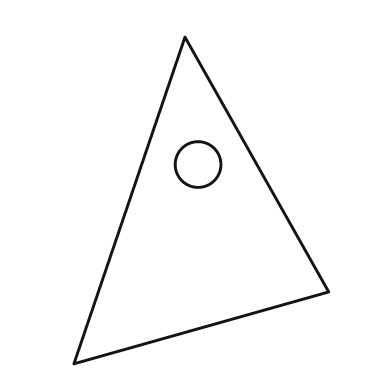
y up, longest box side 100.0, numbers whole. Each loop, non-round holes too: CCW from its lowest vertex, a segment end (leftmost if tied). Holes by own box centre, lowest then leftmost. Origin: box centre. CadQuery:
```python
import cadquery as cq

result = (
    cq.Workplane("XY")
    .moveTo(-39.0, -50.0)
    .lineTo(39.0, -28.0)
    .lineTo(-5.0, 50.0)
    .close()
    .moveTo(-1.0, 11.0)
    .circle(7.0)
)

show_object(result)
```